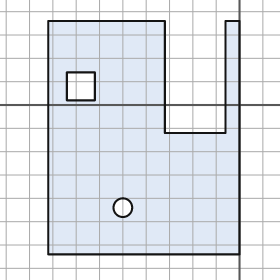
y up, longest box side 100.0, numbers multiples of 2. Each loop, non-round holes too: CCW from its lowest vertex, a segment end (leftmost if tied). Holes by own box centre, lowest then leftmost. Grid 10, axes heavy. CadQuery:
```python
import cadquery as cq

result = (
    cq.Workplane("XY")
    .moveTo(-82.0, -64.0)
    .lineTo(0.0, -64.0)
    .lineTo(0.0, 36.0)
    .lineTo(-6.0, 36.0)
    .lineTo(-6.0, -12.0)
    .lineTo(-32.0, -12.0)
    .lineTo(-32.0, 36.0)
    .lineTo(-82.0, 36.0)
    .close()
    .moveTo(-50.0, -44.0)
    .circle(4.0)
    .moveTo(-74.0, 2.0)
    .lineTo(-62.0, 2.0)
    .lineTo(-62.0, 14.0)
    .lineTo(-74.0, 14.0)
    .close()
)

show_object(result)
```